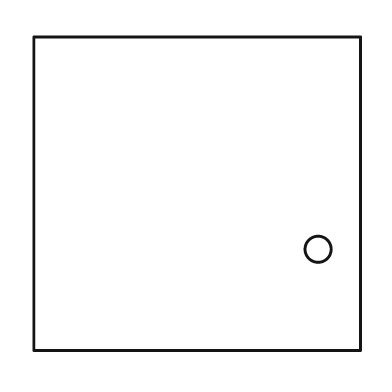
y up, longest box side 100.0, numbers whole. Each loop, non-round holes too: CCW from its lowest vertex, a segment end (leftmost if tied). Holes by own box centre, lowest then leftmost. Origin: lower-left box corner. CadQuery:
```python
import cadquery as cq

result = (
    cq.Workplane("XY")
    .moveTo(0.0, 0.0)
    .lineTo(100.0, 0.0)
    .lineTo(100.0, 96.0)
    .lineTo(0.0, 96.0)
    .close()
    .moveTo(87.0, 31.0)
    .circle(4.0)
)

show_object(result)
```